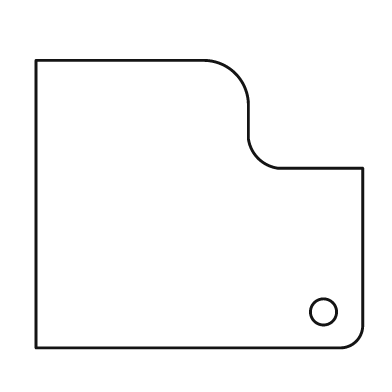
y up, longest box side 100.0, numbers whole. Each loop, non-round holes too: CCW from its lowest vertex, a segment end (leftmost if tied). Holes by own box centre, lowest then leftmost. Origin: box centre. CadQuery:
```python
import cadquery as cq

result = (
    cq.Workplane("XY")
    .moveTo(-50.0, -44.0)
    .lineTo(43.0, -44.0)
    .threePointArc((48.0, -42.0), (50.0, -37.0))
    .lineTo(50.0, 11.0)
    .lineTo(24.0, 11.0)
    .threePointArc((18.0, 14.0), (15.0, 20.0))
    .lineTo(15.0, 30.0)
    .threePointArc((11.0, 40.0), (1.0, 44.0))
    .lineTo(-50.0, 44.0)
    .close()
    .moveTo(38.0, -33.0)
    .circle(4.0)
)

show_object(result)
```